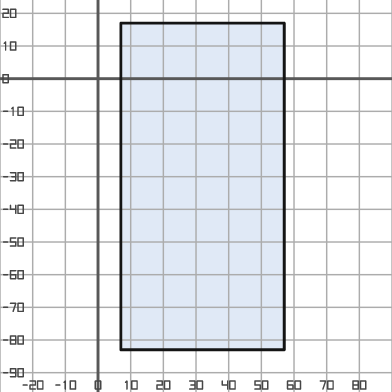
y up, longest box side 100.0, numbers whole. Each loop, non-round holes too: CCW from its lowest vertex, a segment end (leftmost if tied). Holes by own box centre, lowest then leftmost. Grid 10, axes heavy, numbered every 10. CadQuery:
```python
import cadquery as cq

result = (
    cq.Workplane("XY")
    .moveTo(7.0, -83.0)
    .lineTo(57.0, -83.0)
    .lineTo(57.0, 17.0)
    .lineTo(7.0, 17.0)
    .close()
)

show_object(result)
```